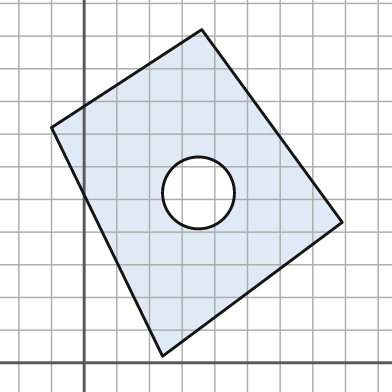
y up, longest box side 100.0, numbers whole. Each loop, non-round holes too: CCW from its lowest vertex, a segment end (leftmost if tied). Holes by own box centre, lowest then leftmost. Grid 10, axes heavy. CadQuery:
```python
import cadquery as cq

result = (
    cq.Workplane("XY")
    .moveTo(24.0, 2.0)
    .lineTo(79.0, 43.0)
    .lineTo(36.0, 102.0)
    .lineTo(-10.0, 72.0)
    .close()
    .moveTo(35.0, 52.0)
    .circle(11.0)
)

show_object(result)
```